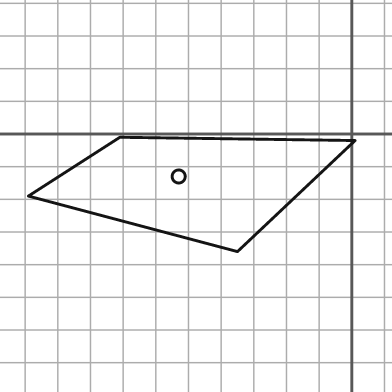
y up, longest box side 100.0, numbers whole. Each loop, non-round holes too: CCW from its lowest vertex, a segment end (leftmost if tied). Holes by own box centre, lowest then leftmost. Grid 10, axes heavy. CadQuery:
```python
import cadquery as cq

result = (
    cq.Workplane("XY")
    .moveTo(-35.0, -36.0)
    .lineTo(1.0, -2.0)
    .lineTo(-71.0, -1.0)
    .lineTo(-99.0, -19.0)
    .close()
    .moveTo(-53.0, -13.0)
    .circle(2.0)
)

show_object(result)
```